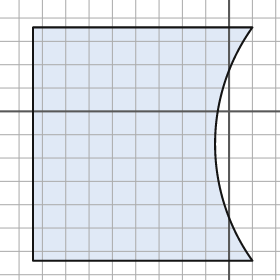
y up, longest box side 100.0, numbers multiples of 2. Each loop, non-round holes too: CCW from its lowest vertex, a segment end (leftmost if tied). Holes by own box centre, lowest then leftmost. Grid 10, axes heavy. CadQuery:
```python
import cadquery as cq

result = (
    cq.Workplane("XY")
    .moveTo(-84.0, -64.0)
    .lineTo(10.0, -64.0)
    .threePointArc((-6.0, -14.0), (10.0, 36.0))
    .lineTo(-84.0, 36.0)
    .close()
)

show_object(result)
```